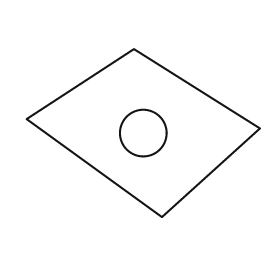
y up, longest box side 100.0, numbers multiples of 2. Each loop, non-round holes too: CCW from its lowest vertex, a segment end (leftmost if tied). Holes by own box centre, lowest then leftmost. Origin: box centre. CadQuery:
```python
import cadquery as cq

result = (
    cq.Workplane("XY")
    .moveTo(8.0, -36.0)
    .lineTo(50.0, 2.0)
    .lineTo(-4.0, 36.0)
    .lineTo(-50.0, 6.0)
    .close()
    .moveTo(0.0, 0.0)
    .circle(10.0)
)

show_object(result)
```